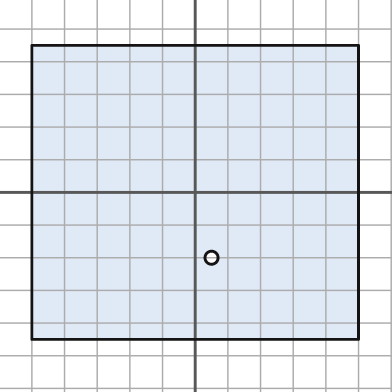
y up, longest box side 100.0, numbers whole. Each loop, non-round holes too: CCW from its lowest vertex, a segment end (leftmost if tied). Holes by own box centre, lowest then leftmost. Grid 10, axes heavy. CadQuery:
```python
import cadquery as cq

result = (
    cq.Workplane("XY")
    .moveTo(-50.0, -45.0)
    .lineTo(50.0, -45.0)
    .lineTo(50.0, 45.0)
    .lineTo(-50.0, 45.0)
    .close()
    .moveTo(5.0, -20.0)
    .circle(2.0)
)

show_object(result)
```